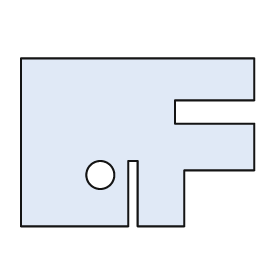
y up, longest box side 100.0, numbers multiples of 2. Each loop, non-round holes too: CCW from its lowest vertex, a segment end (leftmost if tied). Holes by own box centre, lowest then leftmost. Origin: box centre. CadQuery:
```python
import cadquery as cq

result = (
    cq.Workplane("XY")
    .moveTo(-50.0, -36.0)
    .lineTo(-4.0, -36.0)
    .lineTo(-4.0, -8.0)
    .lineTo(0.0, -8.0)
    .lineTo(0.0, -36.0)
    .lineTo(20.0, -36.0)
    .lineTo(20.0, -12.0)
    .lineTo(50.0, -12.0)
    .lineTo(50.0, 8.0)
    .lineTo(16.0, 8.0)
    .lineTo(16.0, 18.0)
    .lineTo(50.0, 18.0)
    .lineTo(50.0, 36.0)
    .lineTo(-50.0, 36.0)
    .close()
    .moveTo(-16.0, -14.0)
    .circle(6.0)
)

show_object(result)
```